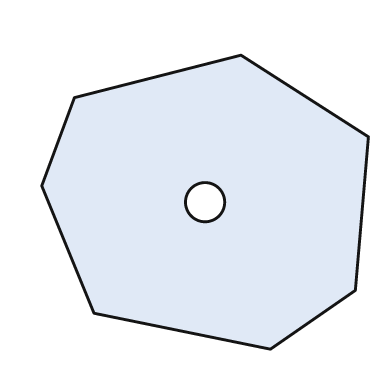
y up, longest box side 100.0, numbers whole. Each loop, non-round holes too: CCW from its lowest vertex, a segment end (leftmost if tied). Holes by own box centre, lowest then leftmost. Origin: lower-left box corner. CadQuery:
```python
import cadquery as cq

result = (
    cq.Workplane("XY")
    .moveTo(70.0, 0.0)
    .lineTo(96.0, 18.0)
    .lineTo(100.0, 65.0)
    .lineTo(61.0, 90.0)
    .lineTo(10.0, 77.0)
    .lineTo(0.0, 50.0)
    .lineTo(16.0, 11.0)
    .close()
    .moveTo(50.0, 45.0)
    .circle(6.0)
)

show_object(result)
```